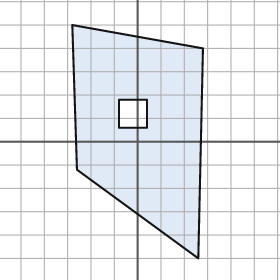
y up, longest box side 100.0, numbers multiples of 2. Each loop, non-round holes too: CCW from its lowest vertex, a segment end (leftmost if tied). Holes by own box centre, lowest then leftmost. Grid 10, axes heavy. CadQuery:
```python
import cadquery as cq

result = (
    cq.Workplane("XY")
    .moveTo(26.0, -50.0)
    .lineTo(28.0, 40.0)
    .lineTo(-28.0, 50.0)
    .lineTo(-26.0, -12.0)
    .close()
    .moveTo(-8.0, 6.0)
    .lineTo(4.0, 6.0)
    .lineTo(4.0, 18.0)
    .lineTo(-8.0, 18.0)
    .close()
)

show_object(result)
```